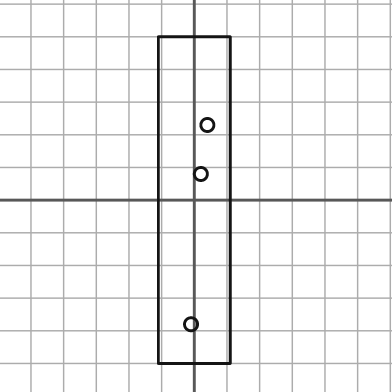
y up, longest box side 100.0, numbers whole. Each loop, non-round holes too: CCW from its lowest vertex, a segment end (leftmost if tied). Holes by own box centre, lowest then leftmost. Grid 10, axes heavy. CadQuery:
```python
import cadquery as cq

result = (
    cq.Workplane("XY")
    .moveTo(-11.0, -50.0)
    .lineTo(11.0, -50.0)
    .lineTo(11.0, 50.0)
    .lineTo(-11.0, 50.0)
    .close()
    .moveTo(-1.0, -38.0)
    .circle(2.0)
    .moveTo(2.0, 8.0)
    .circle(2.0)
    .moveTo(4.0, 23.0)
    .circle(2.0)
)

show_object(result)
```